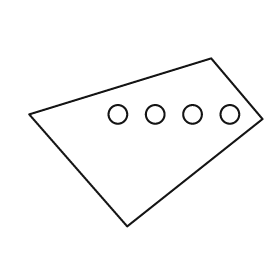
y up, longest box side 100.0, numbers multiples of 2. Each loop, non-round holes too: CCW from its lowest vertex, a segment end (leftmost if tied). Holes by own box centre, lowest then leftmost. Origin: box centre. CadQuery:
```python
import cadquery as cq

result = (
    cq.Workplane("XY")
    .moveTo(-8.0, -36.0)
    .lineTo(50.0, 10.0)
    .lineTo(28.0, 36.0)
    .lineTo(-50.0, 12.0)
    .close()
    .moveTo(-12.0, 12.0)
    .circle(4.0)
    .moveTo(4.0, 12.0)
    .circle(4.0)
    .moveTo(20.0, 12.0)
    .circle(4.0)
    .moveTo(36.0, 12.0)
    .circle(4.0)
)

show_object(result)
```